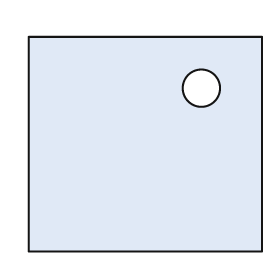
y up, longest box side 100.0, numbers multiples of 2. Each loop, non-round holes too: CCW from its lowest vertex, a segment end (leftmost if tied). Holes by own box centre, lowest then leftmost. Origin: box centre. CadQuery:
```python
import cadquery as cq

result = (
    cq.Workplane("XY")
    .moveTo(-50.0, -46.0)
    .lineTo(50.0, -46.0)
    .lineTo(50.0, 46.0)
    .lineTo(-50.0, 46.0)
    .close()
    .moveTo(24.0, 24.0)
    .circle(8.0)
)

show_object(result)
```